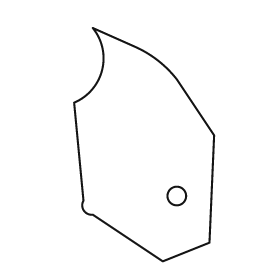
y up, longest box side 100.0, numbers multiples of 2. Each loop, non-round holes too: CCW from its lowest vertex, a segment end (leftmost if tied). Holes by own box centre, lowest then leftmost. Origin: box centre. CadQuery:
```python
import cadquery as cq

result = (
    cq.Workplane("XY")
    .moveTo(8.0, -50.0)
    .lineTo(28.0, -42.0)
    .lineTo(30.0, 4.0)
    .lineTo(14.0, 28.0)
    .threePointArc((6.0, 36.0), (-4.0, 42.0))
    .lineTo(-22.0, 50.0)
    .threePointArc((-18.0, 32.0), (-30.0, 18.0))
    .lineTo(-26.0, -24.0)
    .threePointArc((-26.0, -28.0), (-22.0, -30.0))
    .close()
    .moveTo(14.0, -22.0)
    .circle(4.0)
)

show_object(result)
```